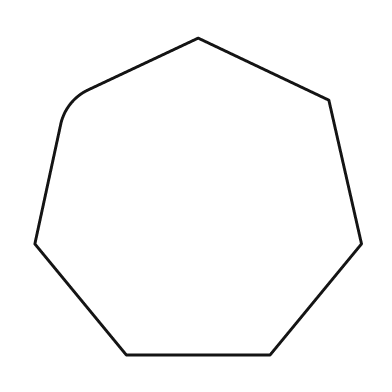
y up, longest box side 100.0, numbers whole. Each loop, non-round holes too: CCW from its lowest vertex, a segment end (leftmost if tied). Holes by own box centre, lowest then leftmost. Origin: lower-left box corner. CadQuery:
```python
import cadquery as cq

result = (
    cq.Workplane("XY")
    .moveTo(28.0, 0.0)
    .lineTo(72.0, 0.0)
    .lineTo(100.0, 34.0)
    .lineTo(90.0, 78.0)
    .lineTo(50.0, 97.0)
    .lineTo(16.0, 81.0)
    .threePointArc((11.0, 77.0), (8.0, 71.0))
    .lineTo(0.0, 34.0)
    .close()
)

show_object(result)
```